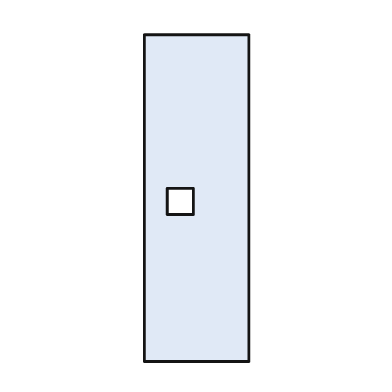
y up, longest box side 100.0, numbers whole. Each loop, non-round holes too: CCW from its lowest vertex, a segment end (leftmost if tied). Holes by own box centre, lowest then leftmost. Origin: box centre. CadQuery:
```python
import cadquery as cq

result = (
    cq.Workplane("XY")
    .moveTo(-16.0, -50.0)
    .lineTo(16.0, -50.0)
    .lineTo(16.0, 50.0)
    .lineTo(-16.0, 50.0)
    .close()
    .moveTo(-9.0, -5.0)
    .lineTo(-1.0, -5.0)
    .lineTo(-1.0, 3.0)
    .lineTo(-9.0, 3.0)
    .close()
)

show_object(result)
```